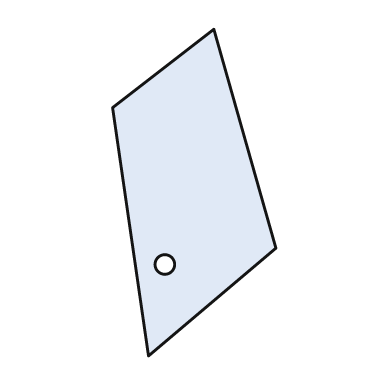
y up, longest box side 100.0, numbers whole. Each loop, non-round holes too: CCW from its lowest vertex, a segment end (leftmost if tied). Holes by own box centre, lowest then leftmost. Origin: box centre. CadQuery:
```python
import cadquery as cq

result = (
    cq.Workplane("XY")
    .moveTo(-14.0, -50.0)
    .lineTo(25.0, -17.0)
    .lineTo(6.0, 50.0)
    .lineTo(-25.0, 26.0)
    .close()
    .moveTo(-9.0, -22.0)
    .circle(3.0)
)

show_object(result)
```